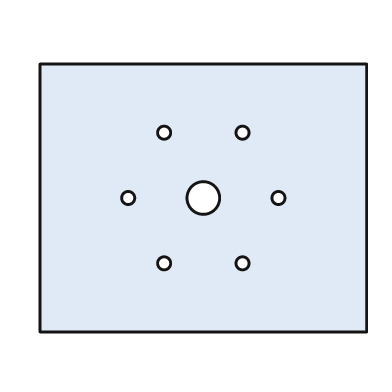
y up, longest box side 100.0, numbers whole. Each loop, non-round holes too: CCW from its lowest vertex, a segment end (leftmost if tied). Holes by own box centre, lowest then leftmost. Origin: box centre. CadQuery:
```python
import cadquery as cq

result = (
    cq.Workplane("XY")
    .moveTo(-50.0, -41.0)
    .lineTo(50.0, -41.0)
    .lineTo(50.0, 41.0)
    .lineTo(-50.0, 41.0)
    .close()
    .moveTo(-12.0, -20.0)
    .circle(2.0)
    .moveTo(12.0, -20.0)
    .circle(2.0)
    .moveTo(-23.0, 0.0)
    .circle(2.0)
    .moveTo(0.0, 0.0)
    .circle(5.0)
    .moveTo(23.0, 0.0)
    .circle(2.0)
    .moveTo(-12.0, 20.0)
    .circle(2.0)
    .moveTo(12.0, 20.0)
    .circle(2.0)
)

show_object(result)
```